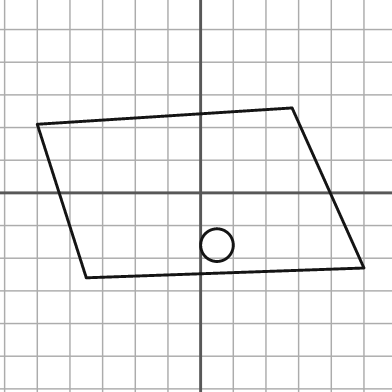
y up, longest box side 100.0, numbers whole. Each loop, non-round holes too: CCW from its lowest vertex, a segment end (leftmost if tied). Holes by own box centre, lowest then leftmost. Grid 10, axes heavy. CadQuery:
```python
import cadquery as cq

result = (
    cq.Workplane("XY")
    .moveTo(-35.0, -26.0)
    .lineTo(50.0, -23.0)
    .lineTo(28.0, 26.0)
    .lineTo(-50.0, 21.0)
    .close()
    .moveTo(5.0, -16.0)
    .circle(5.0)
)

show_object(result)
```